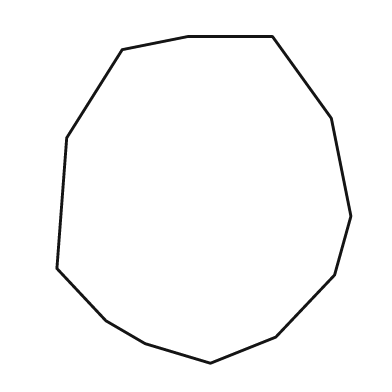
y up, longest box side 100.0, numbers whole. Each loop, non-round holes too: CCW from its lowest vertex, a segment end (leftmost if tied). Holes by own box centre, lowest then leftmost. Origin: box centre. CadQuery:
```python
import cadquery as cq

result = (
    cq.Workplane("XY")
    .moveTo(2.0, -50.0)
    .lineTo(22.0, -42.0)
    .lineTo(40.0, -23.0)
    .lineTo(45.0, -5.0)
    .lineTo(39.0, 25.0)
    .lineTo(21.0, 50.0)
    .lineTo(-5.0, 50.0)
    .lineTo(-25.0, 46.0)
    .lineTo(-42.0, 19.0)
    .lineTo(-45.0, -21.0)
    .lineTo(-30.0, -37.0)
    .lineTo(-18.0, -44.0)
    .close()
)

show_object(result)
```